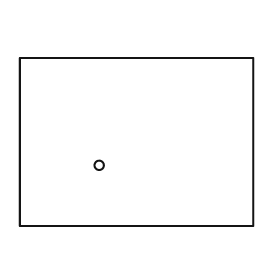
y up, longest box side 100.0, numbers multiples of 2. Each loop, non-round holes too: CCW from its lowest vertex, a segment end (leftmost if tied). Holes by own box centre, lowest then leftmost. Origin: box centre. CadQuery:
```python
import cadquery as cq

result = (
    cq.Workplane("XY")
    .moveTo(-50.0, -36.0)
    .lineTo(50.0, -36.0)
    .lineTo(50.0, 36.0)
    .lineTo(-50.0, 36.0)
    .close()
    .moveTo(-16.0, -10.0)
    .circle(2.0)
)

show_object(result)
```